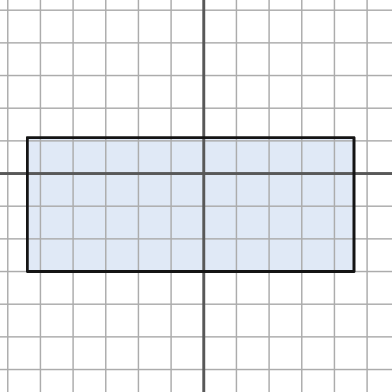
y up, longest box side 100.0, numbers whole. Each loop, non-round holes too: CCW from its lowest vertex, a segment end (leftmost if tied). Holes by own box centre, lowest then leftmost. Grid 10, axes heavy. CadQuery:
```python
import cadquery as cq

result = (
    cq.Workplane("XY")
    .moveTo(-54.0, -30.0)
    .lineTo(46.0, -30.0)
    .lineTo(46.0, 11.0)
    .lineTo(-54.0, 11.0)
    .close()
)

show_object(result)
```